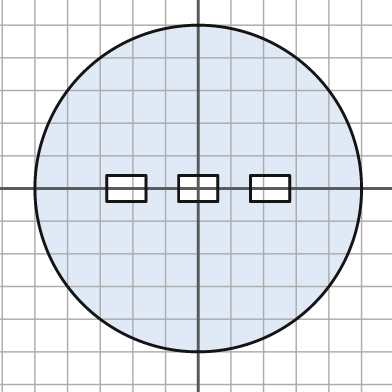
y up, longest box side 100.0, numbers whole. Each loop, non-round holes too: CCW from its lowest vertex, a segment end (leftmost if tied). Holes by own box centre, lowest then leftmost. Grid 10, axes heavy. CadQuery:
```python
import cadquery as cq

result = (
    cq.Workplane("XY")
    .moveTo(0.0, 0.0)
    .circle(50.0)
    .moveTo(-28.0, -4.0)
    .lineTo(-16.0, -4.0)
    .lineTo(-16.0, 4.0)
    .lineTo(-28.0, 4.0)
    .close()
    .moveTo(-6.0, -4.0)
    .lineTo(6.0, -4.0)
    .lineTo(6.0, 4.0)
    .lineTo(-6.0, 4.0)
    .close()
    .moveTo(16.0, -4.0)
    .lineTo(28.0, -4.0)
    .lineTo(28.0, 4.0)
    .lineTo(16.0, 4.0)
    .close()
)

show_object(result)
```